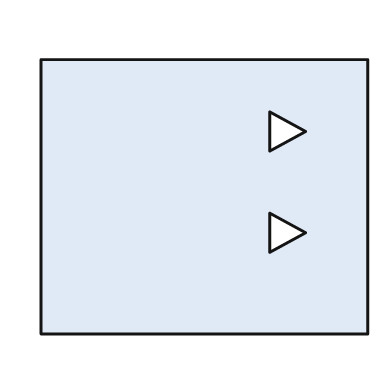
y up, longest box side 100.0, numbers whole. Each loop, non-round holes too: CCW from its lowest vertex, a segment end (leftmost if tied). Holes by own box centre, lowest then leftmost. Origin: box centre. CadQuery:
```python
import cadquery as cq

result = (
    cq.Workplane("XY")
    .moveTo(-50.0, -42.0)
    .lineTo(50.0, -42.0)
    .lineTo(50.0, 42.0)
    .lineTo(-50.0, 42.0)
    .close()
    .moveTo(20.0, -17.0)
    .lineTo(31.0, -11.0)
    .lineTo(20.0, -5.0)
    .close()
    .moveTo(20.0, 14.0)
    .lineTo(31.0, 20.0)
    .lineTo(20.0, 26.0)
    .close()
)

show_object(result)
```